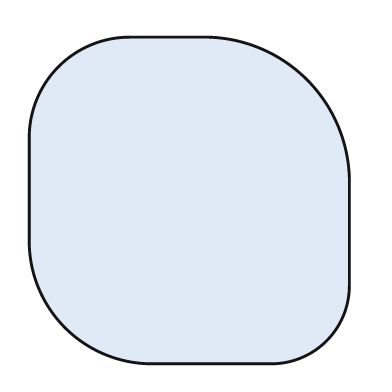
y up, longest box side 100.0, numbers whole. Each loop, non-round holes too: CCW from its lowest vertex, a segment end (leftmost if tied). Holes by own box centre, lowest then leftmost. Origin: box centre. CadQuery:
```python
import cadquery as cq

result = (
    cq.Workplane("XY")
    .moveTo(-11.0, -50.0)
    .lineTo(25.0, -50.0)
    .threePointArc((42.0, -43.0), (49.0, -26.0))
    .lineTo(49.0, 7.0)
    .threePointArc((36.0, 37.0), (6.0, 50.0))
    .lineTo(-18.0, 50.0)
    .threePointArc((-40.0, 41.0), (-49.0, 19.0))
    .lineTo(-49.0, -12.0)
    .threePointArc((-38.0, -39.0), (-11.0, -50.0))
    .close()
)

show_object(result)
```